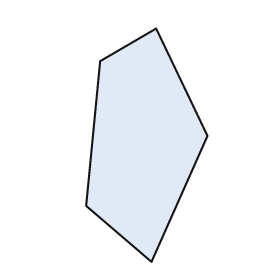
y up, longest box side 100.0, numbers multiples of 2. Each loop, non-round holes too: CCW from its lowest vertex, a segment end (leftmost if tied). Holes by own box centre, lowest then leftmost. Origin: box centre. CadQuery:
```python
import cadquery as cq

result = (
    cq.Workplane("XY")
    .moveTo(2.0, -50.0)
    .lineTo(26.0, 4.0)
    .lineTo(4.0, 50.0)
    .lineTo(-20.0, 36.0)
    .lineTo(-26.0, -26.0)
    .close()
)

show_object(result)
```